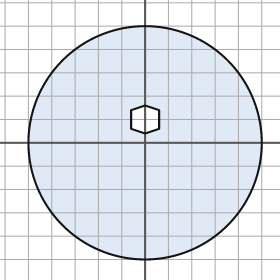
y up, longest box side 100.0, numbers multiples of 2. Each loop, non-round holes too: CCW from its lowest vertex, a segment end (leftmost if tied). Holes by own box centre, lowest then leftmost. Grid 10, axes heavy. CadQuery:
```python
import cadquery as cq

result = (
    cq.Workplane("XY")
    .moveTo(0.0, 0.0)
    .circle(50.0)
    .moveTo(0.0, 4.0)
    .lineTo(6.0, 6.0)
    .lineTo(6.0, 14.0)
    .lineTo(0.0, 16.0)
    .lineTo(-6.0, 14.0)
    .lineTo(-6.0, 6.0)
    .close()
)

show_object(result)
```